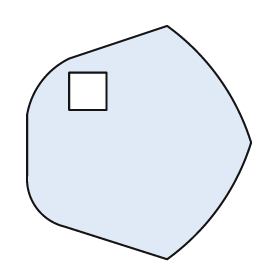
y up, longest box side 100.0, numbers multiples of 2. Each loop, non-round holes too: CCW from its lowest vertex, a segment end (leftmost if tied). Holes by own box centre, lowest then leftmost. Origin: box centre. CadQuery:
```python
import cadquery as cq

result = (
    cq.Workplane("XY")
    .moveTo(12.0, -50.0)
    .threePointArc((34.0, -28.0), (48.0, 0.0))
    .threePointArc((34.0, 28.0), (12.0, 50.0))
    .lineTo(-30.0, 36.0)
    .threePointArc((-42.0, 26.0), (-48.0, 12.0))
    .lineTo(-48.0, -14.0)
    .threePointArc((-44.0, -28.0), (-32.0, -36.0))
    .close()
    .moveTo(-30.0, 14.0)
    .lineTo(-14.0, 14.0)
    .lineTo(-14.0, 30.0)
    .lineTo(-30.0, 30.0)
    .close()
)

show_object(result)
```